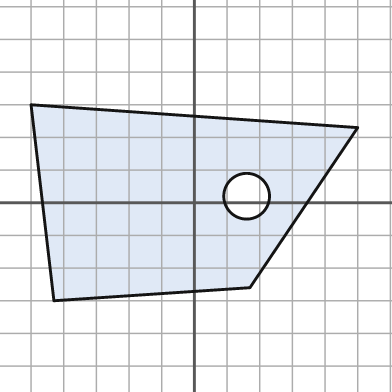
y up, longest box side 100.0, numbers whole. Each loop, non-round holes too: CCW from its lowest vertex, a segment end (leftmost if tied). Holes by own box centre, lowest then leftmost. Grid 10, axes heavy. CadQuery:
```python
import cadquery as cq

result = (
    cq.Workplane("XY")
    .moveTo(-43.0, -30.0)
    .lineTo(17.0, -26.0)
    .lineTo(50.0, 23.0)
    .lineTo(-50.0, 30.0)
    .close()
    .moveTo(16.0, 2.0)
    .circle(7.0)
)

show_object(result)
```